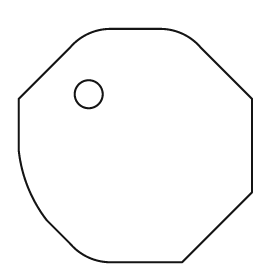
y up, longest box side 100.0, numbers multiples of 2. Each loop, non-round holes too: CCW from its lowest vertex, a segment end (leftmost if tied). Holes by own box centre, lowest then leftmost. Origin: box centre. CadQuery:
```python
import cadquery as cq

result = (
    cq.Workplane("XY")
    .moveTo(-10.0, -50.0)
    .lineTo(20.0, -50.0)
    .lineTo(50.0, -20.0)
    .lineTo(50.0, 20.0)
    .lineTo(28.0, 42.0)
    .threePointArc((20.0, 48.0), (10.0, 50.0))
    .lineTo(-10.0, 50.0)
    .threePointArc((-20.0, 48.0), (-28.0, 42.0))
    .lineTo(-50.0, 20.0)
    .lineTo(-50.0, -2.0)
    .threePointArc((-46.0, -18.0), (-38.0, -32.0))
    .lineTo(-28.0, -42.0)
    .threePointArc((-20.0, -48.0), (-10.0, -50.0))
    .close()
    .moveTo(-20.0, 22.0)
    .circle(6.0)
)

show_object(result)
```